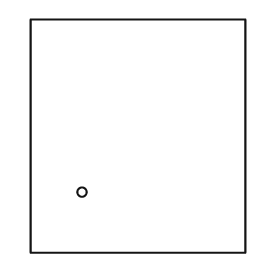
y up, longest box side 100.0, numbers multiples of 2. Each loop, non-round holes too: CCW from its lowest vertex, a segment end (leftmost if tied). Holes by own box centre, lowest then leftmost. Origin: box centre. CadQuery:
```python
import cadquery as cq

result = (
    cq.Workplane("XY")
    .moveTo(-46.0, -50.0)
    .lineTo(46.0, -50.0)
    .lineTo(46.0, 50.0)
    .lineTo(-46.0, 50.0)
    .close()
    .moveTo(-24.0, -24.0)
    .circle(2.0)
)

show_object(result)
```